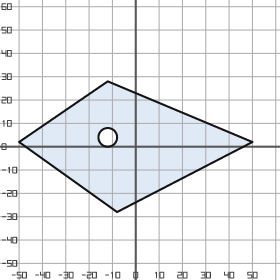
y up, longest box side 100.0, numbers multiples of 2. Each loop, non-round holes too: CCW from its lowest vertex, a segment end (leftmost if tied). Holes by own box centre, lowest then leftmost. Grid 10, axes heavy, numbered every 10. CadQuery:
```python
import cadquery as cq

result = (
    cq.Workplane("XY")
    .moveTo(-8.0, -28.0)
    .lineTo(50.0, 2.0)
    .lineTo(-12.0, 28.0)
    .lineTo(-50.0, 2.0)
    .close()
    .moveTo(-12.0, 4.0)
    .circle(4.0)
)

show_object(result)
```